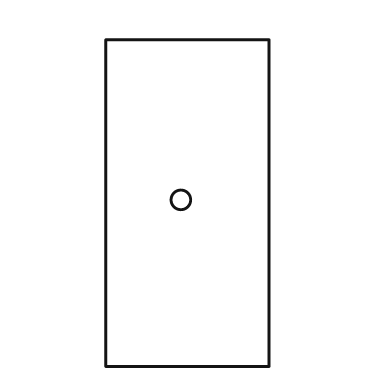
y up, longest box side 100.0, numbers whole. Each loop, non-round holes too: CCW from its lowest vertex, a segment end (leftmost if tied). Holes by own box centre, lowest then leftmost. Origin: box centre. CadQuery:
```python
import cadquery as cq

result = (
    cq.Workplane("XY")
    .moveTo(-25.0, -50.0)
    .lineTo(25.0, -50.0)
    .lineTo(25.0, 50.0)
    .lineTo(-25.0, 50.0)
    .close()
    .moveTo(-2.0, 1.0)
    .circle(3.0)
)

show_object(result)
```